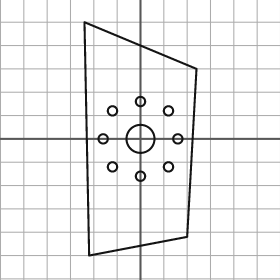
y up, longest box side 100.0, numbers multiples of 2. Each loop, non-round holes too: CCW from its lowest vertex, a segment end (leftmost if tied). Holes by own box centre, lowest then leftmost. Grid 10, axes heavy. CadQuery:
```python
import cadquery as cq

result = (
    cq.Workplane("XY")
    .moveTo(-22.0, -50.0)
    .lineTo(20.0, -42.0)
    .lineTo(24.0, 30.0)
    .lineTo(-24.0, 50.0)
    .close()
    .moveTo(0.0, -16.0)
    .circle(2.0)
    .moveTo(-12.0, -12.0)
    .circle(2.0)
    .moveTo(12.0, -12.0)
    .circle(2.0)
    .moveTo(-16.0, 0.0)
    .circle(2.0)
    .moveTo(0.0, 0.0)
    .circle(6.0)
    .moveTo(16.0, 0.0)
    .circle(2.0)
    .moveTo(-12.0, 12.0)
    .circle(2.0)
    .moveTo(12.0, 12.0)
    .circle(2.0)
    .moveTo(0.0, 16.0)
    .circle(2.0)
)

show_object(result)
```